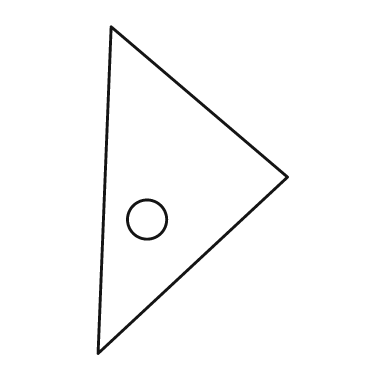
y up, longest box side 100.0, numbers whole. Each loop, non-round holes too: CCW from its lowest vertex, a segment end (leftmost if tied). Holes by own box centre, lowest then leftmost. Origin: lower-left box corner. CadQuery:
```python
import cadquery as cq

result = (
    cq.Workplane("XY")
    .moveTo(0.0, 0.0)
    .lineTo(58.0, 54.0)
    .lineTo(4.0, 100.0)
    .close()
    .moveTo(15.0, 41.0)
    .circle(6.0)
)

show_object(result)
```